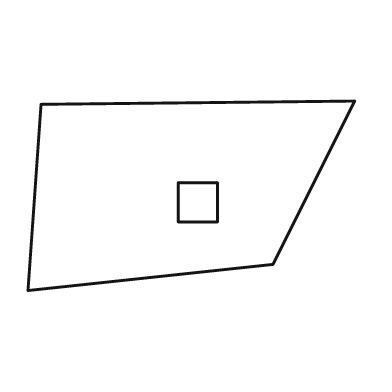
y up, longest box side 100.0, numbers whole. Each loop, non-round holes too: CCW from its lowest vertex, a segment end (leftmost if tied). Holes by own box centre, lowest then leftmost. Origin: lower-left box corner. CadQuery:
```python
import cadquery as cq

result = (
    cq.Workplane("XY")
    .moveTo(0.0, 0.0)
    .lineTo(75.0, 8.0)
    .lineTo(100.0, 58.0)
    .lineTo(4.0, 57.0)
    .close()
    .moveTo(46.0, 21.0)
    .lineTo(58.0, 21.0)
    .lineTo(58.0, 33.0)
    .lineTo(46.0, 33.0)
    .close()
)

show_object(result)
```